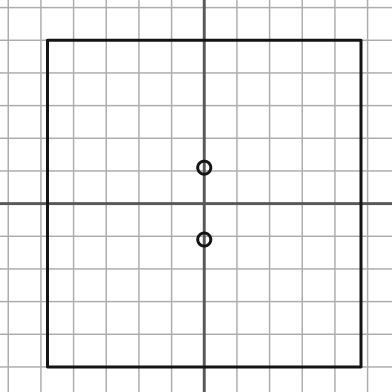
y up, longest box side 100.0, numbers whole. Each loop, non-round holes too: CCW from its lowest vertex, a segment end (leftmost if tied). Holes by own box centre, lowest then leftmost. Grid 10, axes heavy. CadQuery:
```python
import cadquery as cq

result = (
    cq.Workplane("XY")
    .moveTo(-48.0, -50.0)
    .lineTo(48.0, -50.0)
    .lineTo(48.0, 50.0)
    .lineTo(-48.0, 50.0)
    .close()
    .moveTo(0.0, -11.0)
    .circle(2.0)
    .moveTo(0.0, 11.0)
    .circle(2.0)
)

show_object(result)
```